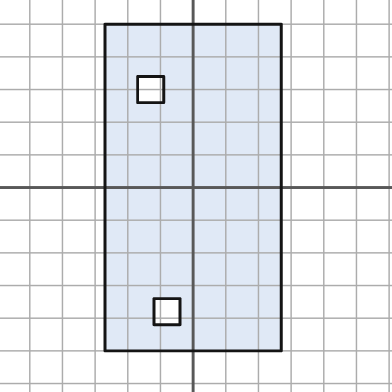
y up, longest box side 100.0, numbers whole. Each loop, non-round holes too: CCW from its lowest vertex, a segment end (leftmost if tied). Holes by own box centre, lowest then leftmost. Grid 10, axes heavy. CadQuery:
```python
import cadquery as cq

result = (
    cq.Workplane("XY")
    .moveTo(-27.0, -50.0)
    .lineTo(27.0, -50.0)
    .lineTo(27.0, 50.0)
    .lineTo(-27.0, 50.0)
    .close()
    .moveTo(-12.0, -42.0)
    .lineTo(-4.0, -42.0)
    .lineTo(-4.0, -34.0)
    .lineTo(-12.0, -34.0)
    .close()
    .moveTo(-17.0, 26.0)
    .lineTo(-9.0, 26.0)
    .lineTo(-9.0, 34.0)
    .lineTo(-17.0, 34.0)
    .close()
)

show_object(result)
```